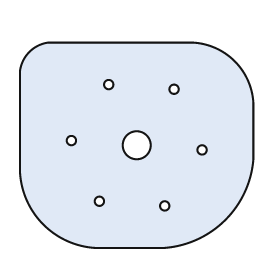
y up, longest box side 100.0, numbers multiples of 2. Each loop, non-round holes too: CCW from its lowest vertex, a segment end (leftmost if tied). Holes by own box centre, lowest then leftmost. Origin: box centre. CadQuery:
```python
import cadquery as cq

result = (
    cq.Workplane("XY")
    .moveTo(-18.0, -44.0)
    .lineTo(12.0, -44.0)
    .threePointArc((38.0, -32.0), (50.0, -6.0))
    .lineTo(50.0, 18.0)
    .threePointArc((42.0, 36.0), (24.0, 44.0))
    .lineTo(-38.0, 44.0)
    .threePointArc((-46.0, 40.0), (-50.0, 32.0))
    .lineTo(-50.0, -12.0)
    .threePointArc((-40.0, -34.0), (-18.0, -44.0))
    .close()
    .moveTo(12.0, -26.0)
    .circle(2.0)
    .moveTo(-16.0, -24.0)
    .circle(2.0)
    .moveTo(28.0, -2.0)
    .circle(2.0)
    .moveTo(0.0, 0.0)
    .circle(6.0)
    .moveTo(-28.0, 2.0)
    .circle(2.0)
    .moveTo(16.0, 24.0)
    .circle(2.0)
    .moveTo(-12.0, 26.0)
    .circle(2.0)
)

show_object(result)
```